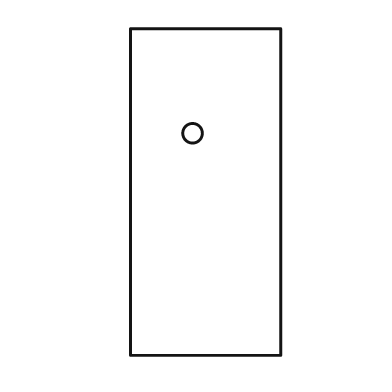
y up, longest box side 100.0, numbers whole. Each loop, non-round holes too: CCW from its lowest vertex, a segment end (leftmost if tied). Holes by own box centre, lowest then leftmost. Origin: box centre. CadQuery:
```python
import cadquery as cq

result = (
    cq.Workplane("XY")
    .moveTo(-23.0, -50.0)
    .lineTo(23.0, -50.0)
    .lineTo(23.0, 50.0)
    .lineTo(-23.0, 50.0)
    .close()
    .moveTo(-4.0, 18.0)
    .circle(3.0)
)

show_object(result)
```